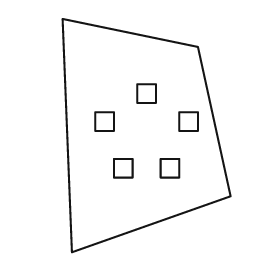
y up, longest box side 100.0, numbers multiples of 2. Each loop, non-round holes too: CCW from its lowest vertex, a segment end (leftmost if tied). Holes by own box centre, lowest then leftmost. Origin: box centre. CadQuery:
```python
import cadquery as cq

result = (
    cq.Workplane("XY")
    .moveTo(-32.0, -50.0)
    .lineTo(36.0, -26.0)
    .lineTo(22.0, 38.0)
    .lineTo(-36.0, 50.0)
    .close()
    .moveTo(-14.0, -18.0)
    .lineTo(-6.0, -18.0)
    .lineTo(-6.0, -10.0)
    .lineTo(-14.0, -10.0)
    .close()
    .moveTo(6.0, -18.0)
    .lineTo(14.0, -18.0)
    .lineTo(14.0, -10.0)
    .lineTo(6.0, -10.0)
    .close()
    .moveTo(-22.0, 2.0)
    .lineTo(-14.0, 2.0)
    .lineTo(-14.0, 10.0)
    .lineTo(-22.0, 10.0)
    .close()
    .moveTo(14.0, 2.0)
    .lineTo(22.0, 2.0)
    .lineTo(22.0, 10.0)
    .lineTo(14.0, 10.0)
    .close()
    .moveTo(-4.0, 14.0)
    .lineTo(4.0, 14.0)
    .lineTo(4.0, 22.0)
    .lineTo(-4.0, 22.0)
    .close()
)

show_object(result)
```